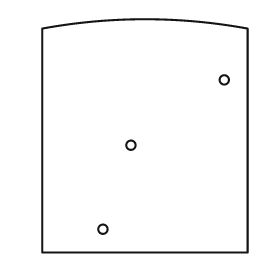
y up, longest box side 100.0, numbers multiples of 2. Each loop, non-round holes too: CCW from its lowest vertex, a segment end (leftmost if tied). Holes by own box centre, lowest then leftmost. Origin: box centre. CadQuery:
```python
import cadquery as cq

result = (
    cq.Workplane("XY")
    .moveTo(-44.0, -50.0)
    .lineTo(44.0, -50.0)
    .lineTo(44.0, 46.0)
    .threePointArc((0.0, 50.0), (-44.0, 46.0))
    .close()
    .moveTo(-18.0, -40.0)
    .circle(2.0)
    .moveTo(-6.0, -4.0)
    .circle(2.0)
    .moveTo(34.0, 24.0)
    .circle(2.0)
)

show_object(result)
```